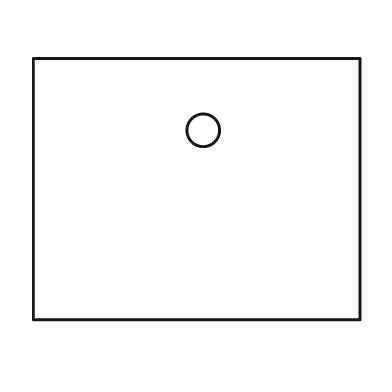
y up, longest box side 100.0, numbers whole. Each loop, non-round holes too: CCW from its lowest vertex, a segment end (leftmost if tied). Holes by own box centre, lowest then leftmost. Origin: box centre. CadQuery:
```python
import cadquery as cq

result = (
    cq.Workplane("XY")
    .moveTo(-50.0, -40.0)
    .lineTo(50.0, -40.0)
    .lineTo(50.0, 40.0)
    .lineTo(-50.0, 40.0)
    .close()
    .moveTo(2.0, 18.0)
    .circle(5.0)
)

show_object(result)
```